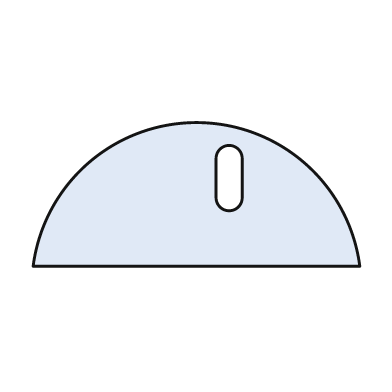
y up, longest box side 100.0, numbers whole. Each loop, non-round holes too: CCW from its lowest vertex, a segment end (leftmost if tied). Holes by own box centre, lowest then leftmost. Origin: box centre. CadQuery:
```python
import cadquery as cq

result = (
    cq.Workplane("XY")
    .moveTo(-50.0, -22.0)
    .lineTo(50.0, -22.0)
    .threePointArc((0.0, 22.0), (-50.0, -22.0))
    .close()
    .moveTo(6.0, -1.0)
    .threePointArc((10.0, -5.0), (14.0, -1.0))
    .lineTo(14.0, 11.0)
    .threePointArc((10.0, 15.0), (6.0, 11.0))
    .close()
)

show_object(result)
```